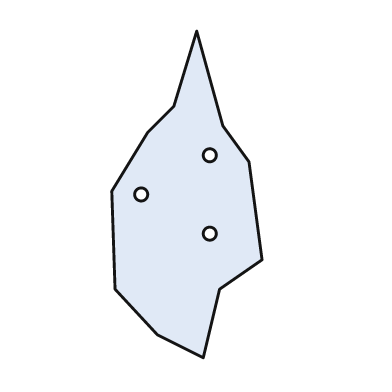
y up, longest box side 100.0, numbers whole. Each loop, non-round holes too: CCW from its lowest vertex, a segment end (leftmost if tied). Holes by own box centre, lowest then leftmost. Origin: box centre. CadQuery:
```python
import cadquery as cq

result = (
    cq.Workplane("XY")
    .moveTo(5.0, -50.0)
    .lineTo(10.0, -29.0)
    .lineTo(23.0, -20.0)
    .lineTo(19.0, 10.0)
    .lineTo(11.0, 21.0)
    .lineTo(3.0, 50.0)
    .lineTo(-4.0, 27.0)
    .lineTo(-12.0, 19.0)
    .lineTo(-23.0, 1.0)
    .lineTo(-22.0, -29.0)
    .lineTo(-9.0, -43.0)
    .close()
    .moveTo(7.0, -12.0)
    .circle(2.0)
    .moveTo(-14.0, 0.0)
    .circle(2.0)
    .moveTo(7.0, 12.0)
    .circle(2.0)
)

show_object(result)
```